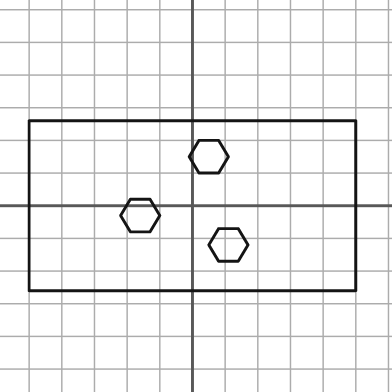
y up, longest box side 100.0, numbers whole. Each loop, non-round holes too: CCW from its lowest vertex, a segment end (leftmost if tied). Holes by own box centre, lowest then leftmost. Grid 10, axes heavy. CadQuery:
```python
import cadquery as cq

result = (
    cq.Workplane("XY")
    .moveTo(-50.0, -26.0)
    .lineTo(50.0, -26.0)
    .lineTo(50.0, 26.0)
    .lineTo(-50.0, 26.0)
    .close()
    .moveTo(8.0, -17.0)
    .lineTo(14.0, -17.0)
    .lineTo(17.0, -12.0)
    .lineTo(14.0, -7.0)
    .lineTo(8.0, -7.0)
    .lineTo(5.0, -12.0)
    .close()
    .moveTo(-19.0, -8.0)
    .lineTo(-13.0, -8.0)
    .lineTo(-10.0, -3.0)
    .lineTo(-13.0, 2.0)
    .lineTo(-19.0, 2.0)
    .lineTo(-22.0, -3.0)
    .close()
    .moveTo(2.0, 10.0)
    .lineTo(8.0, 10.0)
    .lineTo(11.0, 15.0)
    .lineTo(8.0, 20.0)
    .lineTo(2.0, 20.0)
    .lineTo(-1.0, 15.0)
    .close()
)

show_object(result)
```